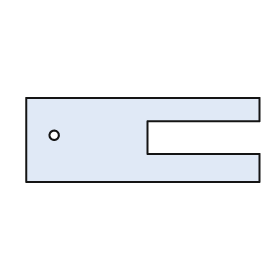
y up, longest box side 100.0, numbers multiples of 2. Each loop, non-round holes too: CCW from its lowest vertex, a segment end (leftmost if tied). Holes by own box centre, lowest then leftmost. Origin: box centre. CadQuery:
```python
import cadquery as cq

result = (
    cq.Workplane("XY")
    .moveTo(-50.0, -18.0)
    .lineTo(50.0, -18.0)
    .lineTo(50.0, -6.0)
    .lineTo(2.0, -6.0)
    .lineTo(2.0, 8.0)
    .lineTo(50.0, 8.0)
    .lineTo(50.0, 18.0)
    .lineTo(-50.0, 18.0)
    .close()
    .moveTo(-38.0, 2.0)
    .circle(2.0)
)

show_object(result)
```